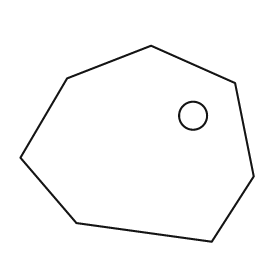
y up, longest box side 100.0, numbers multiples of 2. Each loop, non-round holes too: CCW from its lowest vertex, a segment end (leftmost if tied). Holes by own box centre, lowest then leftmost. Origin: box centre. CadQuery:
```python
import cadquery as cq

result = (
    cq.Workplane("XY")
    .moveTo(32.0, -42.0)
    .lineTo(50.0, -14.0)
    .lineTo(42.0, 26.0)
    .lineTo(6.0, 42.0)
    .lineTo(-30.0, 28.0)
    .lineTo(-50.0, -6.0)
    .lineTo(-26.0, -34.0)
    .close()
    .moveTo(24.0, 12.0)
    .circle(6.0)
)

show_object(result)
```